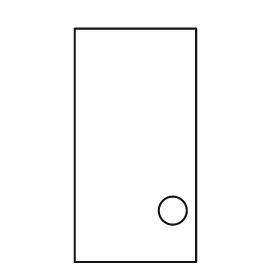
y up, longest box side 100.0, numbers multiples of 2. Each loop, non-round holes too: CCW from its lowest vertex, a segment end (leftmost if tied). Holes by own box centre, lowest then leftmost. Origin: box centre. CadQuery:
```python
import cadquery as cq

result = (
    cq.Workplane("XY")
    .moveTo(-26.0, -50.0)
    .lineTo(26.0, -50.0)
    .lineTo(26.0, 50.0)
    .lineTo(-26.0, 50.0)
    .close()
    .moveTo(16.0, -28.0)
    .circle(6.0)
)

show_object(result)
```